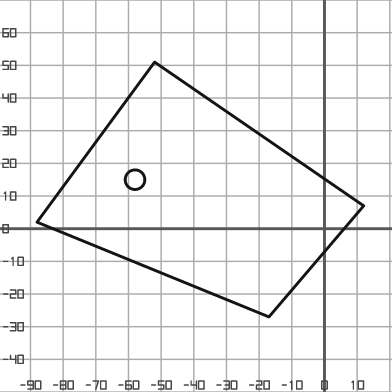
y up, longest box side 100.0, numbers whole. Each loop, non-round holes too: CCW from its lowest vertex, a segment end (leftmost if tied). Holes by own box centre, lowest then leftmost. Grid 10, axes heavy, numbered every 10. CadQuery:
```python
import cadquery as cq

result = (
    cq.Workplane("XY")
    .moveTo(-17.0, -27.0)
    .lineTo(12.0, 7.0)
    .lineTo(-52.0, 51.0)
    .lineTo(-88.0, 2.0)
    .close()
    .moveTo(-58.0, 15.0)
    .circle(3.0)
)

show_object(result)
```